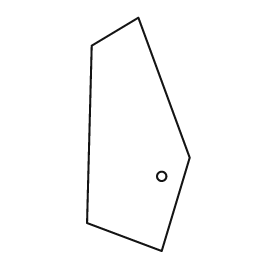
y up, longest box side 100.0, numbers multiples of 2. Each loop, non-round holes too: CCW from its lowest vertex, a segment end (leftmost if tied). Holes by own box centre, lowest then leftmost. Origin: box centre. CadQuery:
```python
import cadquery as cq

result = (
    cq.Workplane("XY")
    .moveTo(10.0, -50.0)
    .lineTo(22.0, -10.0)
    .lineTo(0.0, 50.0)
    .lineTo(-20.0, 38.0)
    .lineTo(-22.0, -38.0)
    .close()
    .moveTo(10.0, -18.0)
    .circle(2.0)
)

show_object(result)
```